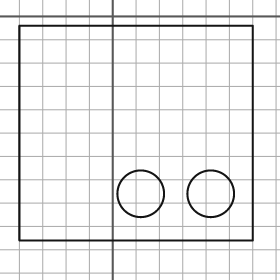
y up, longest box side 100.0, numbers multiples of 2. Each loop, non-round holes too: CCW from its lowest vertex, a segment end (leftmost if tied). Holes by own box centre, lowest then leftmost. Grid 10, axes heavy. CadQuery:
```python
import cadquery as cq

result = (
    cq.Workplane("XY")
    .moveTo(-40.0, -96.0)
    .lineTo(60.0, -96.0)
    .lineTo(60.0, -4.0)
    .lineTo(-40.0, -4.0)
    .close()
    .moveTo(12.0, -76.0)
    .circle(10.0)
    .moveTo(42.0, -76.0)
    .circle(10.0)
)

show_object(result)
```